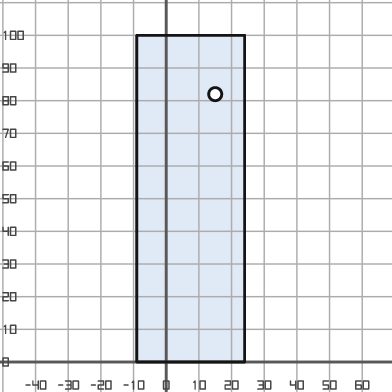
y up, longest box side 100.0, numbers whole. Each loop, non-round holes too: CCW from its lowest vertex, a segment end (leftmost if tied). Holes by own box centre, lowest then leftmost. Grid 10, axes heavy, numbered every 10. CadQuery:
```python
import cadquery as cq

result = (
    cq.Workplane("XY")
    .moveTo(-9.0, 0.0)
    .lineTo(24.0, 0.0)
    .lineTo(24.0, 100.0)
    .lineTo(-9.0, 100.0)
    .close()
    .moveTo(15.0, 82.0)
    .circle(2.0)
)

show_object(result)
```